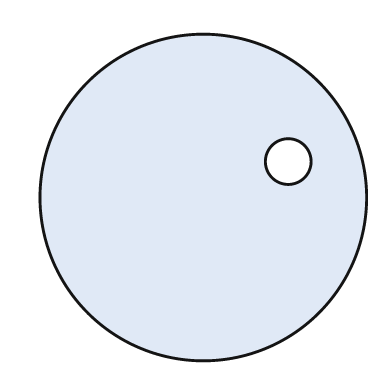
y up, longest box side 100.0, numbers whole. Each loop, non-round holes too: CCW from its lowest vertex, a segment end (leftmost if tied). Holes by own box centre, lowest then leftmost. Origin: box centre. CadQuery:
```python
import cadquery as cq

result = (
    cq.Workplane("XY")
    .moveTo(0.0, 0.0)
    .circle(50.0)
    .moveTo(26.0, 11.0)
    .circle(7.0)
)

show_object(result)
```